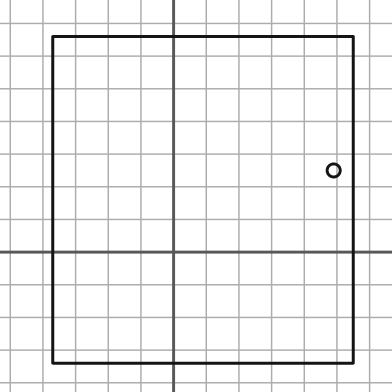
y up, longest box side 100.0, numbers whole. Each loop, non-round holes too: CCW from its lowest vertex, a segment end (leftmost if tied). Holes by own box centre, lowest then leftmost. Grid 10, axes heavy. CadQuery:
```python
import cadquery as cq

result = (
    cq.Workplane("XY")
    .moveTo(-37.0, -34.0)
    .lineTo(55.0, -34.0)
    .lineTo(55.0, 66.0)
    .lineTo(-37.0, 66.0)
    .close()
    .moveTo(49.0, 25.0)
    .circle(2.0)
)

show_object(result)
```